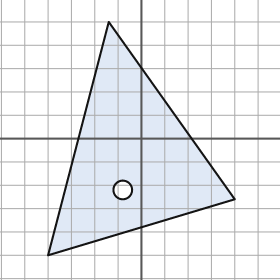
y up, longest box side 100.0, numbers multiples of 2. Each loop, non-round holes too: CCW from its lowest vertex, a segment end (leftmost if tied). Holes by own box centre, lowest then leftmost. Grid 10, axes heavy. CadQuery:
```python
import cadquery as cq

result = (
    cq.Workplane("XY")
    .moveTo(-40.0, -50.0)
    .lineTo(40.0, -26.0)
    .lineTo(-14.0, 50.0)
    .close()
    .moveTo(-8.0, -22.0)
    .circle(4.0)
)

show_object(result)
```